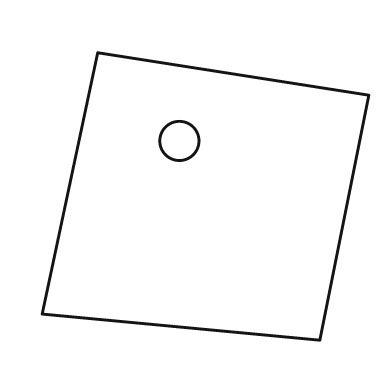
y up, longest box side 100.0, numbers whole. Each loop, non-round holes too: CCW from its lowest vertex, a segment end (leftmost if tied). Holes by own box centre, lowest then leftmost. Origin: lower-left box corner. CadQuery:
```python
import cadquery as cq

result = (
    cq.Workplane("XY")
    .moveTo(85.0, 0.0)
    .lineTo(100.0, 75.0)
    .lineTo(17.0, 88.0)
    .lineTo(0.0, 8.0)
    .close()
    .moveTo(42.0, 61.0)
    .circle(6.0)
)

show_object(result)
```